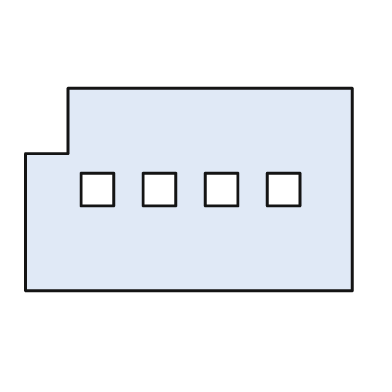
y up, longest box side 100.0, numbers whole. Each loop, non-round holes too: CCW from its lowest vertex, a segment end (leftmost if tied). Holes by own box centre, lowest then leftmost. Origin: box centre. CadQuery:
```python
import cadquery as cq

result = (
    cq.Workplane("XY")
    .moveTo(-50.0, -31.0)
    .lineTo(50.0, -31.0)
    .lineTo(50.0, 31.0)
    .lineTo(-37.0, 31.0)
    .lineTo(-37.0, 11.0)
    .lineTo(-50.0, 11.0)
    .close()
    .moveTo(-33.0, -5.0)
    .lineTo(-23.0, -5.0)
    .lineTo(-23.0, 5.0)
    .lineTo(-33.0, 5.0)
    .close()
    .moveTo(-14.0, -5.0)
    .lineTo(-4.0, -5.0)
    .lineTo(-4.0, 5.0)
    .lineTo(-14.0, 5.0)
    .close()
    .moveTo(5.0, -5.0)
    .lineTo(15.0, -5.0)
    .lineTo(15.0, 5.0)
    .lineTo(5.0, 5.0)
    .close()
    .moveTo(24.0, -5.0)
    .lineTo(34.0, -5.0)
    .lineTo(34.0, 5.0)
    .lineTo(24.0, 5.0)
    .close()
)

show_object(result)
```